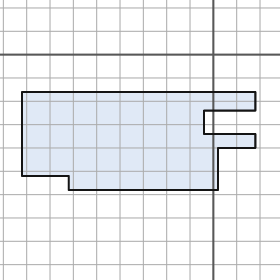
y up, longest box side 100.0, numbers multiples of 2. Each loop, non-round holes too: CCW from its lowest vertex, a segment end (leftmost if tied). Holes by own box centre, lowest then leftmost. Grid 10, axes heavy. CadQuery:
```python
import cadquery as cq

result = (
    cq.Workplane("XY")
    .moveTo(-62.0, -58.0)
    .lineTo(2.0, -58.0)
    .lineTo(2.0, -40.0)
    .lineTo(18.0, -40.0)
    .lineTo(18.0, -34.0)
    .lineTo(-4.0, -34.0)
    .lineTo(-4.0, -24.0)
    .lineTo(18.0, -24.0)
    .lineTo(18.0, -16.0)
    .lineTo(-82.0, -16.0)
    .lineTo(-82.0, -52.0)
    .lineTo(-62.0, -52.0)
    .close()
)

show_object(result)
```